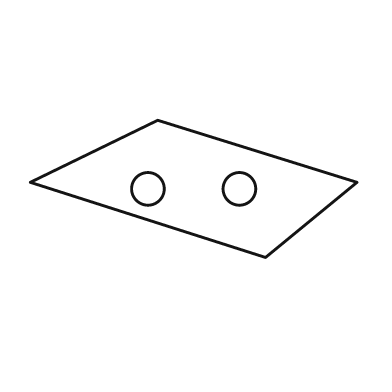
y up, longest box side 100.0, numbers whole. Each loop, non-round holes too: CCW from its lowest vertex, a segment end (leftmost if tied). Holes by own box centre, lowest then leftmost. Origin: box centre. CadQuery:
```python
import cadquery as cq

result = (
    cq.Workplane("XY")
    .moveTo(22.0, -21.0)
    .lineTo(50.0, 2.0)
    .lineTo(-11.0, 21.0)
    .lineTo(-50.0, 2.0)
    .close()
    .moveTo(-14.0, 0.0)
    .circle(5.0)
    .moveTo(14.0, 0.0)
    .circle(5.0)
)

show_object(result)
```